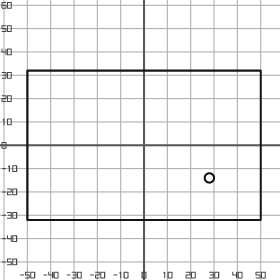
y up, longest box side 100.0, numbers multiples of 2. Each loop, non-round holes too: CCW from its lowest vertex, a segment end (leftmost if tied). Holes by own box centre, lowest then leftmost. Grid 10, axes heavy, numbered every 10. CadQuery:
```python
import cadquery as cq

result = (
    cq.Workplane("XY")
    .moveTo(-50.0, -32.0)
    .lineTo(50.0, -32.0)
    .lineTo(50.0, 32.0)
    .lineTo(-50.0, 32.0)
    .close()
    .moveTo(28.0, -14.0)
    .circle(2.0)
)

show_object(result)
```